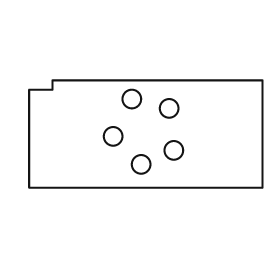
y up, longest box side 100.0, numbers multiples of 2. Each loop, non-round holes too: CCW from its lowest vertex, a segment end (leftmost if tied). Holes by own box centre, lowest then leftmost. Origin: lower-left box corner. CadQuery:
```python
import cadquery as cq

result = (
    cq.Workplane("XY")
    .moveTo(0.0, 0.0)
    .lineTo(100.0, 0.0)
    .lineTo(100.0, 46.0)
    .lineTo(10.0, 46.0)
    .lineTo(10.0, 42.0)
    .lineTo(0.0, 42.0)
    .close()
    .moveTo(48.0, 10.0)
    .circle(4.0)
    .moveTo(62.0, 16.0)
    .circle(4.0)
    .moveTo(36.0, 22.0)
    .circle(4.0)
    .moveTo(60.0, 34.0)
    .circle(4.0)
    .moveTo(44.0, 38.0)
    .circle(4.0)
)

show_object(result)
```